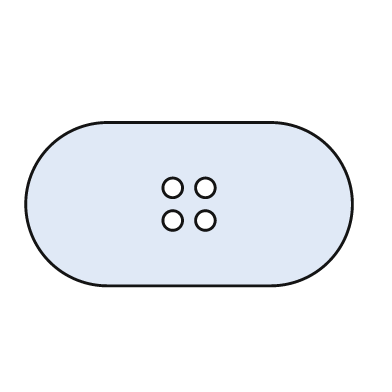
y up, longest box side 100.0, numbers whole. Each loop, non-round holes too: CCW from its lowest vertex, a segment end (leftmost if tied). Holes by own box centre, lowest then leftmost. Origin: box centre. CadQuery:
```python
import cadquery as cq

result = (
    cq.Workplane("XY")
    .moveTo(-25.0, -25.0)
    .lineTo(25.0, -25.0)
    .threePointArc((50.0, 0.0), (25.0, 25.0))
    .lineTo(-25.0, 25.0)
    .threePointArc((-50.0, 0.0), (-25.0, -25.0))
    .close()
    .moveTo(-5.0, -5.0)
    .circle(3.0)
    .moveTo(5.0, -5.0)
    .circle(3.0)
    .moveTo(-5.0, 5.0)
    .circle(3.0)
    .moveTo(5.0, 5.0)
    .circle(3.0)
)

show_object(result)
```